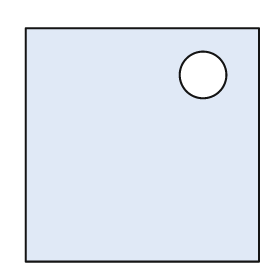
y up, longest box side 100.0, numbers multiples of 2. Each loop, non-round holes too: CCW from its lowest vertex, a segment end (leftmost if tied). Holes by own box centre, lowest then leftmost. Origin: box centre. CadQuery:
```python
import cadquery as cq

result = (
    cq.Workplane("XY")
    .moveTo(-50.0, -50.0)
    .lineTo(50.0, -50.0)
    .lineTo(50.0, 50.0)
    .lineTo(-50.0, 50.0)
    .close()
    .moveTo(26.0, 30.0)
    .circle(10.0)
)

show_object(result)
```